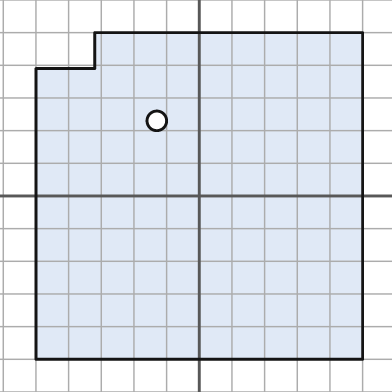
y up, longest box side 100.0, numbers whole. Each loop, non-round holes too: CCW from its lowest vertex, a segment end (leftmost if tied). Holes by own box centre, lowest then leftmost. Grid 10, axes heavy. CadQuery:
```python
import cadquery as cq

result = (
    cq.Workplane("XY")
    .moveTo(-50.0, -50.0)
    .lineTo(50.0, -50.0)
    .lineTo(50.0, 50.0)
    .lineTo(-32.0, 50.0)
    .lineTo(-32.0, 39.0)
    .lineTo(-50.0, 39.0)
    .close()
    .moveTo(-13.0, 23.0)
    .circle(3.0)
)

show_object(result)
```